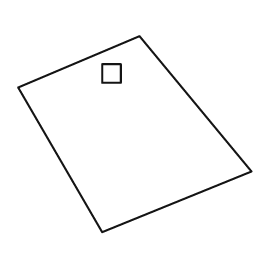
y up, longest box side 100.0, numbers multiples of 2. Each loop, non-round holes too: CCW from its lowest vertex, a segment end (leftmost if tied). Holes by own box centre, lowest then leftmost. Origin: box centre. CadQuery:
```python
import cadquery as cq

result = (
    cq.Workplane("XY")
    .moveTo(-14.0, -42.0)
    .lineTo(50.0, -16.0)
    .lineTo(2.0, 42.0)
    .lineTo(-50.0, 20.0)
    .close()
    .moveTo(-14.0, 22.0)
    .lineTo(-6.0, 22.0)
    .lineTo(-6.0, 30.0)
    .lineTo(-14.0, 30.0)
    .close()
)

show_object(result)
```